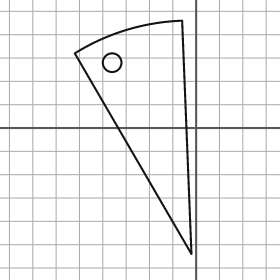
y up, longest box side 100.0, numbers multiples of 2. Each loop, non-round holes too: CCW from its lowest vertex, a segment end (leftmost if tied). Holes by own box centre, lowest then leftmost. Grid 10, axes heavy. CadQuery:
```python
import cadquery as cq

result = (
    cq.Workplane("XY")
    .moveTo(-2.0, -54.0)
    .lineTo(-6.0, 46.0)
    .threePointArc((-30.0, 42.0), (-52.0, 32.0))
    .close()
    .moveTo(-36.0, 28.0)
    .circle(4.0)
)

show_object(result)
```